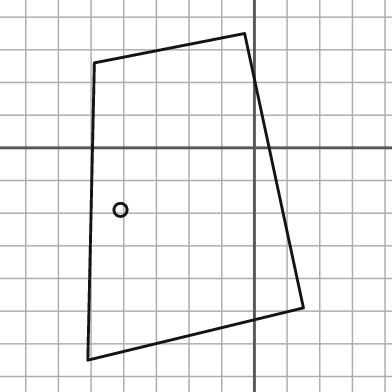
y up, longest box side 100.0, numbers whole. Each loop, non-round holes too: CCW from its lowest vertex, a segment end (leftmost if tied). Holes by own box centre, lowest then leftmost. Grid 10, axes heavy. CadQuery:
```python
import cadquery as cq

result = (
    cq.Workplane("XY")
    .moveTo(-51.0, -65.0)
    .lineTo(15.0, -49.0)
    .lineTo(-3.0, 35.0)
    .lineTo(-49.0, 26.0)
    .close()
    .moveTo(-41.0, -19.0)
    .circle(2.0)
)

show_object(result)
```